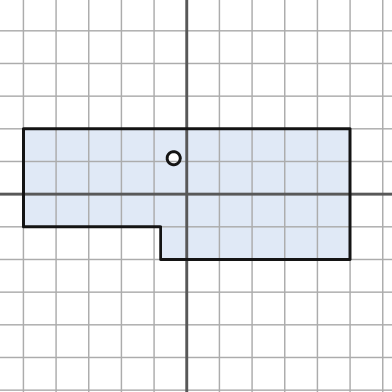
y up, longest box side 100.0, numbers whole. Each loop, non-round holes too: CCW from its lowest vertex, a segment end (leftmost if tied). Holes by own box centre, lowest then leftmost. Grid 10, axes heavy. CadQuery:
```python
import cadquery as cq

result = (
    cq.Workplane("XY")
    .moveTo(-8.0, -20.0)
    .lineTo(50.0, -20.0)
    .lineTo(50.0, 20.0)
    .lineTo(-50.0, 20.0)
    .lineTo(-50.0, -10.0)
    .lineTo(-8.0, -10.0)
    .close()
    .moveTo(-4.0, 11.0)
    .circle(2.0)
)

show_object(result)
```